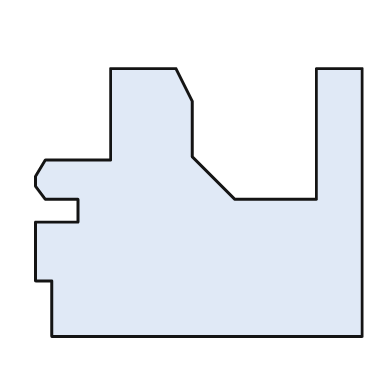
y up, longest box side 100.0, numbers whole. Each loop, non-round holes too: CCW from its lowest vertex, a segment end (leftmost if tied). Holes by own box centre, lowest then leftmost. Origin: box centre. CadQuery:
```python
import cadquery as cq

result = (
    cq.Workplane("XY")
    .moveTo(-45.0, -41.0)
    .lineTo(50.0, -41.0)
    .lineTo(50.0, 41.0)
    .lineTo(36.0, 41.0)
    .lineTo(36.0, 1.0)
    .lineTo(11.0, 1.0)
    .lineTo(-2.0, 14.0)
    .lineTo(-2.0, 31.0)
    .lineTo(-7.0, 41.0)
    .lineTo(-27.0, 41.0)
    .lineTo(-27.0, 13.0)
    .lineTo(-47.0, 13.0)
    .lineTo(-50.0, 8.0)
    .lineTo(-50.0, 5.0)
    .lineTo(-47.0, 1.0)
    .lineTo(-37.0, 1.0)
    .lineTo(-37.0, -6.0)
    .lineTo(-50.0, -6.0)
    .lineTo(-50.0, -24.0)
    .lineTo(-45.0, -24.0)
    .close()
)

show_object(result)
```